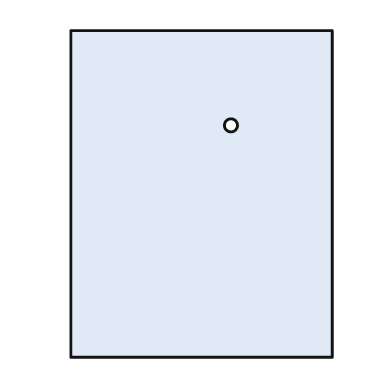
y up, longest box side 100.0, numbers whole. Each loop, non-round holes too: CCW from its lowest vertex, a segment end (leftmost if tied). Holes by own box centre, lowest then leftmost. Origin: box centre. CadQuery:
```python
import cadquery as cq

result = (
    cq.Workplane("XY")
    .moveTo(-40.0, -50.0)
    .lineTo(40.0, -50.0)
    .lineTo(40.0, 50.0)
    .lineTo(-40.0, 50.0)
    .close()
    .moveTo(9.0, 21.0)
    .circle(2.0)
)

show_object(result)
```